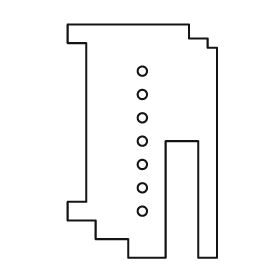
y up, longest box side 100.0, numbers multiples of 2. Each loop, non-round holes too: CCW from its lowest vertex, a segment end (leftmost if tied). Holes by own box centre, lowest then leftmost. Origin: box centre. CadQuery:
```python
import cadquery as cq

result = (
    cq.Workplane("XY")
    .moveTo(-6.0, -50.0)
    .lineTo(10.0, -50.0)
    .lineTo(10.0, 0.0)
    .lineTo(24.0, 0.0)
    .lineTo(24.0, -50.0)
    .lineTo(32.0, -50.0)
    .lineTo(32.0, 40.0)
    .lineTo(28.0, 40.0)
    .lineTo(28.0, 44.0)
    .lineTo(20.0, 44.0)
    .lineTo(20.0, 50.0)
    .lineTo(-32.0, 50.0)
    .lineTo(-32.0, 42.0)
    .lineTo(-24.0, 42.0)
    .lineTo(-24.0, -26.0)
    .lineTo(-32.0, -26.0)
    .lineTo(-32.0, -34.0)
    .lineTo(-20.0, -34.0)
    .lineTo(-20.0, -42.0)
    .lineTo(-6.0, -42.0)
    .close()
    .moveTo(0.0, -30.0)
    .circle(2.0)
    .moveTo(0.0, -20.0)
    .circle(2.0)
    .moveTo(0.0, -10.0)
    .circle(2.0)
    .moveTo(0.0, 0.0)
    .circle(2.0)
    .moveTo(0.0, 10.0)
    .circle(2.0)
    .moveTo(0.0, 20.0)
    .circle(2.0)
    .moveTo(0.0, 30.0)
    .circle(2.0)
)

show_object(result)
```